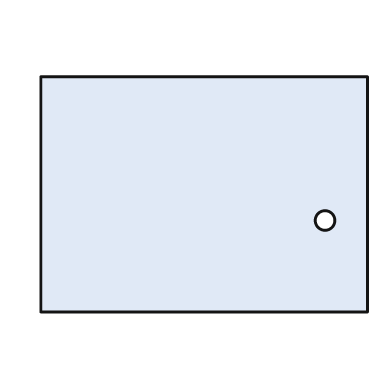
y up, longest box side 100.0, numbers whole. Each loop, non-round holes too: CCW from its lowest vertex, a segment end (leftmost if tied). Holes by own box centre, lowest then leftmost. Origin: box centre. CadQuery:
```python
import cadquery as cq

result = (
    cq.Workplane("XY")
    .moveTo(-50.0, -36.0)
    .lineTo(50.0, -36.0)
    .lineTo(50.0, 36.0)
    .lineTo(-50.0, 36.0)
    .close()
    .moveTo(37.0, -8.0)
    .circle(3.0)
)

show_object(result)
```